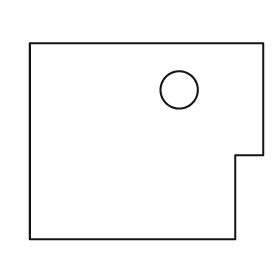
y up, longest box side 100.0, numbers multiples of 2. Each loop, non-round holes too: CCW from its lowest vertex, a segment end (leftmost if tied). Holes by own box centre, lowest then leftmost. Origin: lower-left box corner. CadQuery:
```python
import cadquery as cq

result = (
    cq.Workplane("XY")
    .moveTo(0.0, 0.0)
    .lineTo(88.0, 0.0)
    .lineTo(88.0, 36.0)
    .lineTo(100.0, 36.0)
    .lineTo(100.0, 84.0)
    .lineTo(0.0, 84.0)
    .close()
    .moveTo(64.0, 64.0)
    .circle(8.0)
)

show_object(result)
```